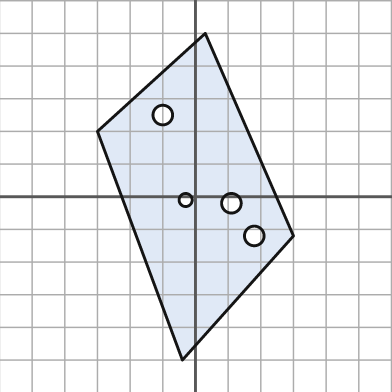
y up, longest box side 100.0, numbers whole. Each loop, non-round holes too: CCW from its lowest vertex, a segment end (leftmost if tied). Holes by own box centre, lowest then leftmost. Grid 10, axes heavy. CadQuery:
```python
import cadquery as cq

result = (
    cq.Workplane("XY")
    .moveTo(-4.0, -50.0)
    .lineTo(30.0, -12.0)
    .lineTo(3.0, 50.0)
    .lineTo(-30.0, 20.0)
    .close()
    .moveTo(18.0, -12.0)
    .circle(3.0)
    .moveTo(11.0, -2.0)
    .circle(3.0)
    .moveTo(-3.0, -1.0)
    .circle(2.0)
    .moveTo(-10.0, 25.0)
    .circle(3.0)
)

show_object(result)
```